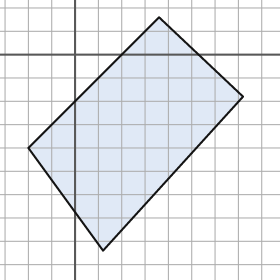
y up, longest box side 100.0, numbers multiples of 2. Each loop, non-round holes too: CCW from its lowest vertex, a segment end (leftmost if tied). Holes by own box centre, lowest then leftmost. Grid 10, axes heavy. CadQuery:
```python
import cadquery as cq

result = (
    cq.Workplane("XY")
    .moveTo(12.0, -84.0)
    .lineTo(72.0, -18.0)
    .lineTo(36.0, 16.0)
    .lineTo(-20.0, -40.0)
    .close()
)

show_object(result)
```